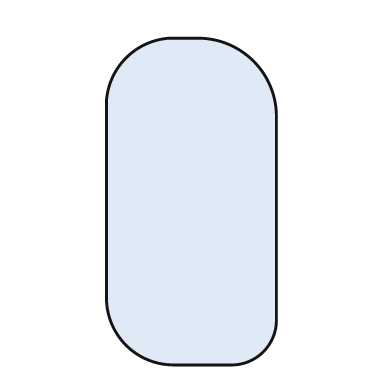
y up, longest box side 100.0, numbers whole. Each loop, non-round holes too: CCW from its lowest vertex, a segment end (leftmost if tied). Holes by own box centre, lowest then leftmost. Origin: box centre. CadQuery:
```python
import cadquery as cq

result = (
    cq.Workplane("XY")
    .moveTo(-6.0, -50.0)
    .lineTo(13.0, -50.0)
    .threePointArc((22.0, -46.0), (26.0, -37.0))
    .lineTo(26.0, 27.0)
    .threePointArc((19.0, 43.0), (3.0, 50.0))
    .lineTo(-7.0, 50.0)
    .threePointArc((-20.0, 44.0), (-26.0, 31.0))
    .lineTo(-26.0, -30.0)
    .threePointArc((-20.0, -44.0), (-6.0, -50.0))
    .close()
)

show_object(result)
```